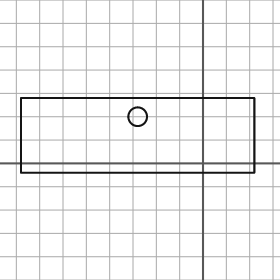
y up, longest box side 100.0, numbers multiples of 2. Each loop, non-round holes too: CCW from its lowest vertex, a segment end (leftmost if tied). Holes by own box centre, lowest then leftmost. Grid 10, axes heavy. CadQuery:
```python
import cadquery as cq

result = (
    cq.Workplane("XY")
    .moveTo(-78.0, -4.0)
    .lineTo(22.0, -4.0)
    .lineTo(22.0, 28.0)
    .lineTo(-78.0, 28.0)
    .close()
    .moveTo(-28.0, 20.0)
    .circle(4.0)
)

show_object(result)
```